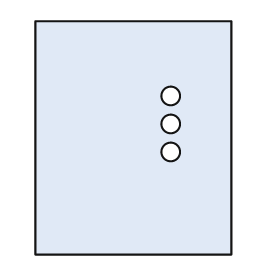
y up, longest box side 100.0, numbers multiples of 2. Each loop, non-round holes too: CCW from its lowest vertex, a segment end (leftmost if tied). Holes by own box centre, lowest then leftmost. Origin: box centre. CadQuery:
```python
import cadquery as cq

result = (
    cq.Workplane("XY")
    .moveTo(-42.0, -50.0)
    .lineTo(42.0, -50.0)
    .lineTo(42.0, 50.0)
    .lineTo(-42.0, 50.0)
    .close()
    .moveTo(16.0, -6.0)
    .circle(4.0)
    .moveTo(16.0, 6.0)
    .circle(4.0)
    .moveTo(16.0, 18.0)
    .circle(4.0)
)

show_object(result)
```